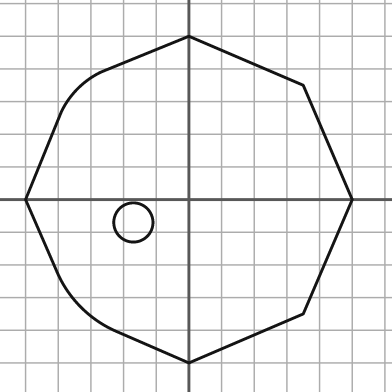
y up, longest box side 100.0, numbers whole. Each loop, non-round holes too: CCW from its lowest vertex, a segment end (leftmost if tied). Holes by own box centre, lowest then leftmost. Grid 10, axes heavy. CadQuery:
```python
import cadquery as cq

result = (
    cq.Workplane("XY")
    .moveTo(0.0, -50.0)
    .lineTo(35.0, -35.0)
    .lineTo(50.0, 0.0)
    .lineTo(35.0, 35.0)
    .lineTo(0.0, 50.0)
    .lineTo(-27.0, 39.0)
    .threePointArc((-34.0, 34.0), (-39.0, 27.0))
    .lineTo(-50.0, 0.0)
    .lineTo(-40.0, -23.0)
    .threePointArc((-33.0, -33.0), (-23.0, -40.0))
    .close()
    .moveTo(-17.0, -7.0)
    .circle(6.0)
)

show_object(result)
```